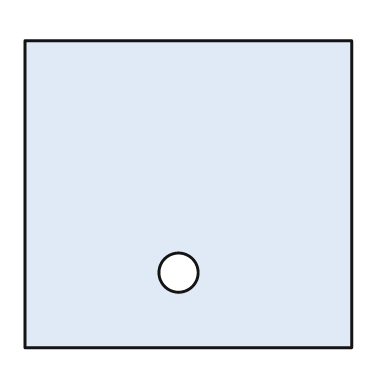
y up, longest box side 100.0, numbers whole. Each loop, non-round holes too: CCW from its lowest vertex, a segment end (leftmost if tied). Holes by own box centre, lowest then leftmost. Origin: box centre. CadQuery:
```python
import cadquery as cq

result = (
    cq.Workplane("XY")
    .moveTo(-50.0, -47.0)
    .lineTo(50.0, -47.0)
    .lineTo(50.0, 47.0)
    .lineTo(-50.0, 47.0)
    .close()
    .moveTo(-3.0, -24.0)
    .circle(6.0)
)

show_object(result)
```